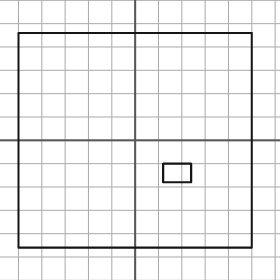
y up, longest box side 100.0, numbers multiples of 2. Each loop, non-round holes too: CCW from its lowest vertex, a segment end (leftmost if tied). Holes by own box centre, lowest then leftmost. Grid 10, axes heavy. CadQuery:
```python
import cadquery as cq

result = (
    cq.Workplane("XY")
    .moveTo(-50.0, -46.0)
    .lineTo(50.0, -46.0)
    .lineTo(50.0, 46.0)
    .lineTo(-50.0, 46.0)
    .close()
    .moveTo(12.0, -18.0)
    .lineTo(24.0, -18.0)
    .lineTo(24.0, -10.0)
    .lineTo(12.0, -10.0)
    .close()
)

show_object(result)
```